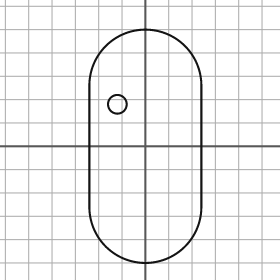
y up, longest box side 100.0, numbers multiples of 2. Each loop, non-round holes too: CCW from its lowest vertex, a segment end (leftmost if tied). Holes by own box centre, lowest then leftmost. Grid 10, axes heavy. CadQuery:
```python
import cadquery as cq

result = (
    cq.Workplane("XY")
    .moveTo(-24.0, -26.0)
    .threePointArc((0.0, -50.0), (24.0, -26.0))
    .lineTo(24.0, 26.0)
    .threePointArc((0.0, 50.0), (-24.0, 26.0))
    .close()
    .moveTo(-12.0, 18.0)
    .circle(4.0)
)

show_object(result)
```